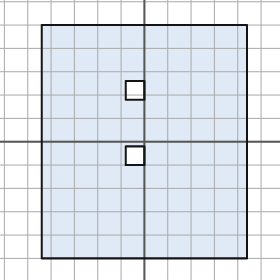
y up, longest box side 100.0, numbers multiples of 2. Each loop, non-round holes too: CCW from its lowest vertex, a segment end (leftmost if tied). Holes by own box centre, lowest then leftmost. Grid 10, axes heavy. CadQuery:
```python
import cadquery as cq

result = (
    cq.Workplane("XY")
    .moveTo(-44.0, -50.0)
    .lineTo(44.0, -50.0)
    .lineTo(44.0, 50.0)
    .lineTo(-44.0, 50.0)
    .close()
    .moveTo(-8.0, -10.0)
    .lineTo(0.0, -10.0)
    .lineTo(0.0, -2.0)
    .lineTo(-8.0, -2.0)
    .close()
    .moveTo(-8.0, 18.0)
    .lineTo(0.0, 18.0)
    .lineTo(0.0, 26.0)
    .lineTo(-8.0, 26.0)
    .close()
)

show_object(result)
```